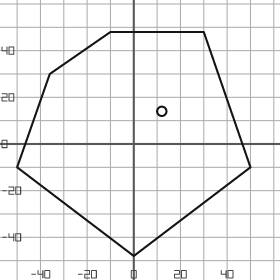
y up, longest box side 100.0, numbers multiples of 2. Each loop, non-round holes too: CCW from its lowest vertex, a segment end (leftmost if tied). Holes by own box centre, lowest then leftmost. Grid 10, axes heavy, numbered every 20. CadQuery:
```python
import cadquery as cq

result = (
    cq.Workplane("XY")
    .moveTo(0.0, -48.0)
    .lineTo(50.0, -10.0)
    .lineTo(30.0, 48.0)
    .lineTo(-10.0, 48.0)
    .lineTo(-36.0, 30.0)
    .lineTo(-50.0, -10.0)
    .close()
    .moveTo(12.0, 14.0)
    .circle(2.0)
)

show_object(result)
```